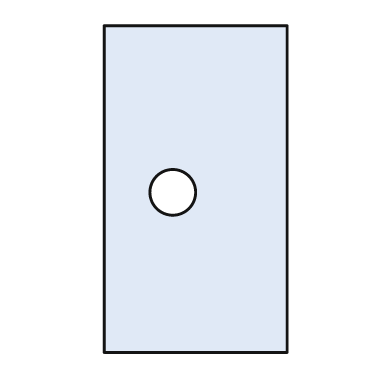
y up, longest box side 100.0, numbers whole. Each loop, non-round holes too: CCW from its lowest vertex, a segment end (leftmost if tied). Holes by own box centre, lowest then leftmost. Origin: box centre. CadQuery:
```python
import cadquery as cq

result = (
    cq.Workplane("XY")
    .moveTo(-28.0, -50.0)
    .lineTo(28.0, -50.0)
    .lineTo(28.0, 50.0)
    .lineTo(-28.0, 50.0)
    .close()
    .moveTo(-7.0, -1.0)
    .circle(7.0)
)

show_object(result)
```